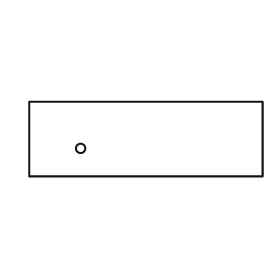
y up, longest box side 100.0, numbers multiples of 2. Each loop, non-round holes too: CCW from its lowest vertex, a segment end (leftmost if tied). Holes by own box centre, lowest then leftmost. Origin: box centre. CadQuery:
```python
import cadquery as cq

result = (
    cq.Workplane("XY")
    .moveTo(-50.0, -16.0)
    .lineTo(50.0, -16.0)
    .lineTo(50.0, 16.0)
    .lineTo(-50.0, 16.0)
    .close()
    .moveTo(-28.0, -4.0)
    .circle(2.0)
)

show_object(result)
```